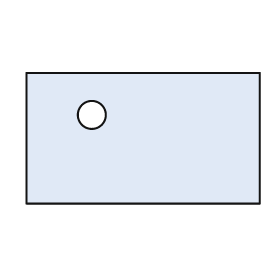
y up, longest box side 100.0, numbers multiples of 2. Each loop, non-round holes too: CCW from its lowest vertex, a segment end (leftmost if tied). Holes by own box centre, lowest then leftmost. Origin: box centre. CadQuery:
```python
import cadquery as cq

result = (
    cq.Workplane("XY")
    .moveTo(-50.0, -28.0)
    .lineTo(50.0, -28.0)
    .lineTo(50.0, 28.0)
    .lineTo(-50.0, 28.0)
    .close()
    .moveTo(-22.0, 10.0)
    .circle(6.0)
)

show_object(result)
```